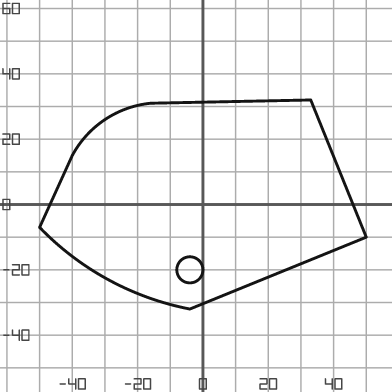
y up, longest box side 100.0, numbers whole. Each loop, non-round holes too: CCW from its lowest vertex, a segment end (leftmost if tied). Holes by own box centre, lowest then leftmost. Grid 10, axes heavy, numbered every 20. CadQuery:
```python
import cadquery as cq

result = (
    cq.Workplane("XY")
    .moveTo(-4.0, -32.0)
    .lineTo(50.0, -10.0)
    .lineTo(33.0, 32.0)
    .lineTo(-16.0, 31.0)
    .threePointArc((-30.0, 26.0), (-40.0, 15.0))
    .lineTo(-50.0, -7.0)
    .threePointArc((-29.0, -23.0), (-4.0, -32.0))
    .close()
    .moveTo(-4.0, -20.0)
    .circle(4.0)
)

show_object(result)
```